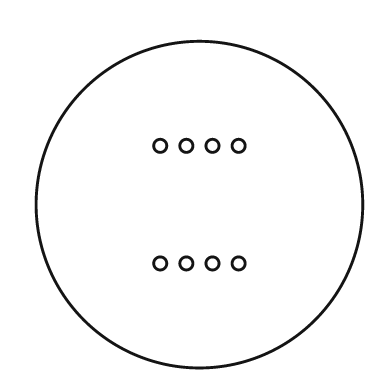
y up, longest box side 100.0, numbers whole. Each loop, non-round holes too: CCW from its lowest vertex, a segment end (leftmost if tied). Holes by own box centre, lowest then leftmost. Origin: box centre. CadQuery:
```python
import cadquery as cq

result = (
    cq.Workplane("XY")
    .moveTo(0.0, 0.0)
    .circle(50.0)
    .moveTo(-12.0, -18.0)
    .circle(2.0)
    .moveTo(-4.0, -18.0)
    .circle(2.0)
    .moveTo(4.0, -18.0)
    .circle(2.0)
    .moveTo(12.0, -18.0)
    .circle(2.0)
    .moveTo(-12.0, 18.0)
    .circle(2.0)
    .moveTo(-4.0, 18.0)
    .circle(2.0)
    .moveTo(4.0, 18.0)
    .circle(2.0)
    .moveTo(12.0, 18.0)
    .circle(2.0)
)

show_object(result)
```